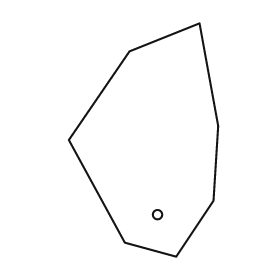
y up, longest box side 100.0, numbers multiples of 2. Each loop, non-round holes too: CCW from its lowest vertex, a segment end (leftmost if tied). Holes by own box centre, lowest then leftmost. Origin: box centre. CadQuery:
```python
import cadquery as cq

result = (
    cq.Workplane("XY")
    .moveTo(14.0, -50.0)
    .lineTo(30.0, -26.0)
    .lineTo(32.0, 6.0)
    .lineTo(24.0, 50.0)
    .lineTo(-6.0, 38.0)
    .lineTo(-32.0, 0.0)
    .lineTo(-8.0, -44.0)
    .close()
    .moveTo(6.0, -32.0)
    .circle(2.0)
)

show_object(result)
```